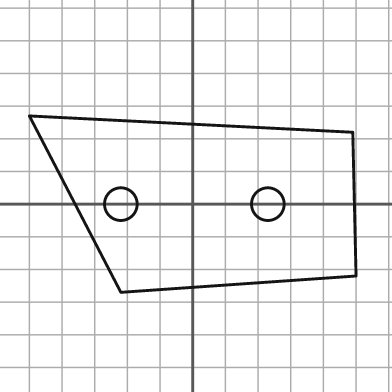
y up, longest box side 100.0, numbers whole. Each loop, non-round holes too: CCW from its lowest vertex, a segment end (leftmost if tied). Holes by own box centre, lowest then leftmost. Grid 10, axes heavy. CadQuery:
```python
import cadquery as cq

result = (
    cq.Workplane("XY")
    .moveTo(-22.0, -27.0)
    .lineTo(50.0, -22.0)
    .lineTo(49.0, 22.0)
    .lineTo(-50.0, 27.0)
    .close()
    .moveTo(-22.0, 0.0)
    .circle(5.0)
    .moveTo(23.0, 0.0)
    .circle(5.0)
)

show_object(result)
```